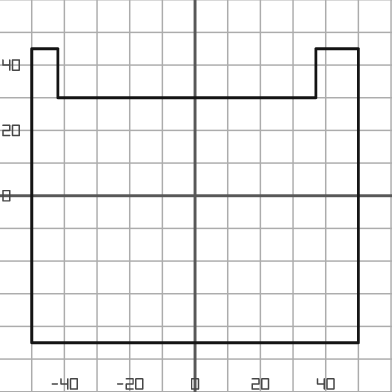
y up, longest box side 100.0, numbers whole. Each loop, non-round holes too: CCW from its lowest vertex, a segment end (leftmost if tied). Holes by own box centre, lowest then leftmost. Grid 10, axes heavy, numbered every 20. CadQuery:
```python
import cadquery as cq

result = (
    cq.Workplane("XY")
    .moveTo(-50.0, -45.0)
    .lineTo(50.0, -45.0)
    .lineTo(50.0, 45.0)
    .lineTo(37.0, 45.0)
    .lineTo(37.0, 30.0)
    .lineTo(-42.0, 30.0)
    .lineTo(-42.0, 45.0)
    .lineTo(-50.0, 45.0)
    .close()
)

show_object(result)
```